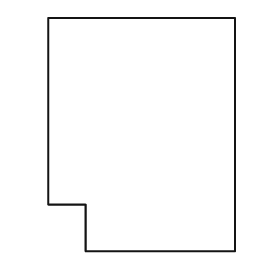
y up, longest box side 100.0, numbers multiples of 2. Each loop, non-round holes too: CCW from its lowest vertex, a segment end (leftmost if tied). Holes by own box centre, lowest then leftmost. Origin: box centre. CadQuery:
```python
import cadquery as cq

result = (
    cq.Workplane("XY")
    .moveTo(-24.0, -50.0)
    .lineTo(40.0, -50.0)
    .lineTo(40.0, 50.0)
    .lineTo(-40.0, 50.0)
    .lineTo(-40.0, -30.0)
    .lineTo(-24.0, -30.0)
    .close()
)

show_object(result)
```